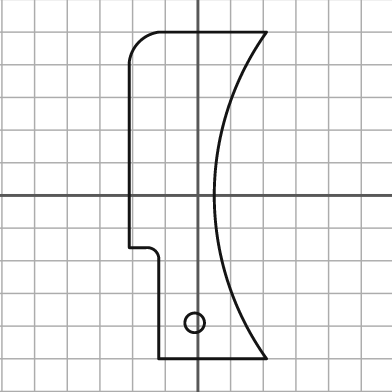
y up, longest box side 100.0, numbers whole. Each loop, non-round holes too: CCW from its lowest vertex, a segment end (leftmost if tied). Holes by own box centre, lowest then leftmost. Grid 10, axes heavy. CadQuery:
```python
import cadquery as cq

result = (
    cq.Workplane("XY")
    .moveTo(-12.0, -50.0)
    .lineTo(21.0, -50.0)
    .threePointArc((5.0, 0.0), (21.0, 50.0))
    .lineTo(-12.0, 50.0)
    .threePointArc((-18.0, 47.0), (-21.0, 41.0))
    .lineTo(-21.0, -16.0)
    .lineTo(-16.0, -16.0)
    .threePointArc((-13.0, -17.0), (-12.0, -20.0))
    .close()
    .moveTo(-1.0, -39.0)
    .circle(3.0)
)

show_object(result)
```